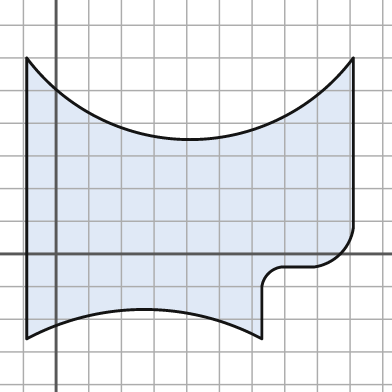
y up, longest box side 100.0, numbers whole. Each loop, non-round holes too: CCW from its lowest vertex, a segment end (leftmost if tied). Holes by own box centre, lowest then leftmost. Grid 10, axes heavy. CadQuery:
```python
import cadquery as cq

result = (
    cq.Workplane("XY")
    .moveTo(-9.0, -26.0)
    .threePointArc((27.0, -17.0), (63.0, -26.0))
    .lineTo(63.0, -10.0)
    .threePointArc((65.0, -6.0), (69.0, -4.0))
    .lineTo(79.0, -4.0)
    .threePointArc((87.0, 0.0), (91.0, 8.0))
    .lineTo(91.0, 60.0)
    .threePointArc((41.0, 35.0), (-9.0, 60.0))
    .close()
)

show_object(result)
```